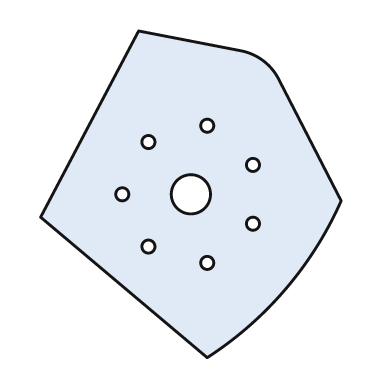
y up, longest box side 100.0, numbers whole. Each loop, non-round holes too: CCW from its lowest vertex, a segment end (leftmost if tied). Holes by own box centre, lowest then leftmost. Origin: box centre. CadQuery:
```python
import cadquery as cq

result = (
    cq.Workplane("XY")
    .moveTo(5.0, -50.0)
    .threePointArc((29.0, -29.0), (46.0, -2.0))
    .lineTo(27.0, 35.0)
    .threePointArc((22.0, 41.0), (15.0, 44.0))
    .lineTo(-16.0, 50.0)
    .lineTo(-46.0, -7.0)
    .close()
    .moveTo(5.0, -21.0)
    .circle(2.0)
    .moveTo(-13.0, -16.0)
    .circle(2.0)
    .moveTo(19.0, -9.0)
    .circle(2.0)
    .moveTo(-21.0, 0.0)
    .circle(2.0)
    .moveTo(0.0, 0.0)
    .circle(6.0)
    .moveTo(19.0, 9.0)
    .circle(2.0)
    .moveTo(-13.0, 16.0)
    .circle(2.0)
    .moveTo(5.0, 21.0)
    .circle(2.0)
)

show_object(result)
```